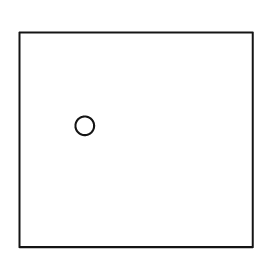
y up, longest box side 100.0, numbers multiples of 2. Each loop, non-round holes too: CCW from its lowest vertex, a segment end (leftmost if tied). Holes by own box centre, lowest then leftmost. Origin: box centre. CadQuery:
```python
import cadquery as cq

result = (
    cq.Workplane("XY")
    .moveTo(-50.0, -46.0)
    .lineTo(50.0, -46.0)
    .lineTo(50.0, 46.0)
    .lineTo(-50.0, 46.0)
    .close()
    .moveTo(-22.0, 6.0)
    .circle(4.0)
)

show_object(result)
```